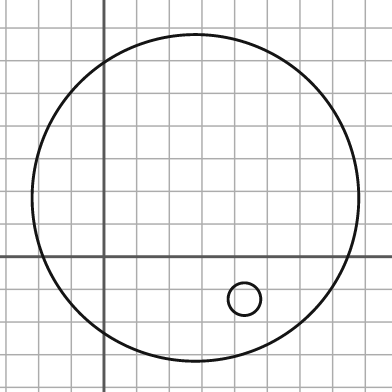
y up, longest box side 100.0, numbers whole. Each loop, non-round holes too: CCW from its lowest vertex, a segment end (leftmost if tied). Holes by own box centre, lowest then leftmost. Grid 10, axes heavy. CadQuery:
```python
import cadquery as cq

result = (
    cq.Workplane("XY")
    .moveTo(28.0, 18.0)
    .circle(50.0)
    .moveTo(43.0, -13.0)
    .circle(5.0)
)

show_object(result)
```